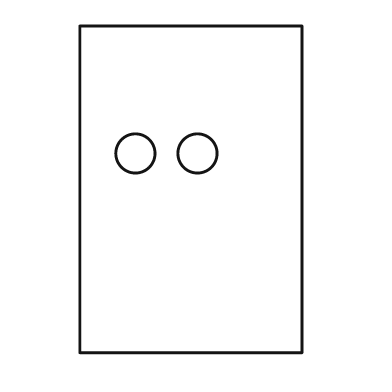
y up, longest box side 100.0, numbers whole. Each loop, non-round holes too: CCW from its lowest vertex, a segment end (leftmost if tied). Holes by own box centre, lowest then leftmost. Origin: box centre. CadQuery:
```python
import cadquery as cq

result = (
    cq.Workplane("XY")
    .moveTo(-34.0, -50.0)
    .lineTo(34.0, -50.0)
    .lineTo(34.0, 50.0)
    .lineTo(-34.0, 50.0)
    .close()
    .moveTo(-17.0, 11.0)
    .circle(6.0)
    .moveTo(2.0, 11.0)
    .circle(6.0)
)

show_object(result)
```